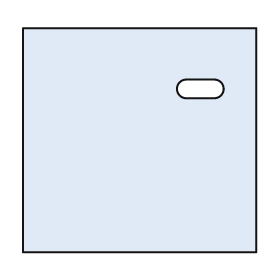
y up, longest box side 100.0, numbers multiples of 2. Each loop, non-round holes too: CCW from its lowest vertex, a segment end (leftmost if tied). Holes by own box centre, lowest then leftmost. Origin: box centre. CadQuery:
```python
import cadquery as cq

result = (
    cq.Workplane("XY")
    .moveTo(-50.0, -48.0)
    .lineTo(50.0, -48.0)
    .lineTo(50.0, 48.0)
    .lineTo(-50.0, 48.0)
    .close()
    .moveTo(20.0, 18.0)
    .lineTo(32.0, 18.0)
    .threePointArc((36.0, 22.0), (32.0, 26.0))
    .lineTo(20.0, 26.0)
    .threePointArc((16.0, 22.0), (20.0, 18.0))
    .close()
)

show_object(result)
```